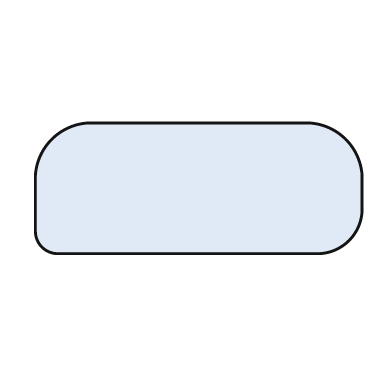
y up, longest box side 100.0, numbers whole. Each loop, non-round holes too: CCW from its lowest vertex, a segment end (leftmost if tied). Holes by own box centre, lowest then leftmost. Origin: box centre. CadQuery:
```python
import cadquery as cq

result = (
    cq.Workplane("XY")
    .moveTo(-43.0, -20.0)
    .lineTo(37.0, -20.0)
    .threePointArc((46.0, -16.0), (50.0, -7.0))
    .lineTo(50.0, 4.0)
    .threePointArc((45.0, 15.0), (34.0, 20.0))
    .lineTo(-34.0, 20.0)
    .threePointArc((-45.0, 15.0), (-50.0, 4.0))
    .lineTo(-50.0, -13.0)
    .threePointArc((-48.0, -18.0), (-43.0, -20.0))
    .close()
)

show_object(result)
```